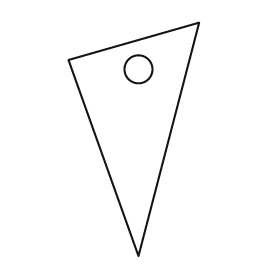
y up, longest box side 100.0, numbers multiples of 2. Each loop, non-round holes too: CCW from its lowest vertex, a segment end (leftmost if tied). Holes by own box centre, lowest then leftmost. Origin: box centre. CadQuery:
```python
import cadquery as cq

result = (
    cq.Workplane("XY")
    .moveTo(2.0, -50.0)
    .lineTo(28.0, 50.0)
    .lineTo(-28.0, 34.0)
    .close()
    .moveTo(2.0, 30.0)
    .circle(6.0)
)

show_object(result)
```